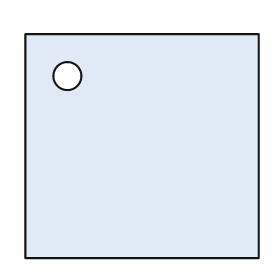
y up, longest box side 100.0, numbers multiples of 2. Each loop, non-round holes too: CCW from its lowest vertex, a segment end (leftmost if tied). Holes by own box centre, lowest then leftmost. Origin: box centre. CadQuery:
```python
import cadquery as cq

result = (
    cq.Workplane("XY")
    .moveTo(-50.0, -48.0)
    .lineTo(50.0, -48.0)
    .lineTo(50.0, 48.0)
    .lineTo(-50.0, 48.0)
    .close()
    .moveTo(-32.0, 30.0)
    .circle(6.0)
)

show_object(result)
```